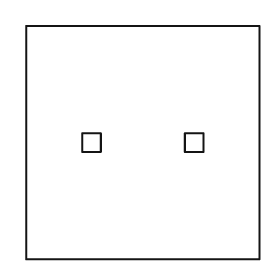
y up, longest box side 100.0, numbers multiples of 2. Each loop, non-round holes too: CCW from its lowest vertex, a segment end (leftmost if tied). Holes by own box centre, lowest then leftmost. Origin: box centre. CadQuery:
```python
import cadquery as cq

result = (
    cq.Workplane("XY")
    .moveTo(-50.0, -50.0)
    .lineTo(50.0, -50.0)
    .lineTo(50.0, 50.0)
    .lineTo(-50.0, 50.0)
    .close()
    .moveTo(-26.0, -4.0)
    .lineTo(-18.0, -4.0)
    .lineTo(-18.0, 4.0)
    .lineTo(-26.0, 4.0)
    .close()
    .moveTo(18.0, -4.0)
    .lineTo(26.0, -4.0)
    .lineTo(26.0, 4.0)
    .lineTo(18.0, 4.0)
    .close()
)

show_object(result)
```